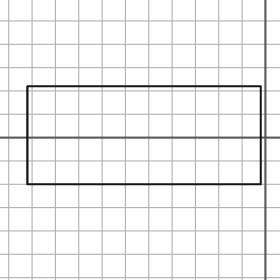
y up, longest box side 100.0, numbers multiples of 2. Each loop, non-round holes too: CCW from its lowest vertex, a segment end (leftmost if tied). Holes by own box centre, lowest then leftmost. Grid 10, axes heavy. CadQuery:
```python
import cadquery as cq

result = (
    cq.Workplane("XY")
    .moveTo(-102.0, -20.0)
    .lineTo(-2.0, -20.0)
    .lineTo(-2.0, 22.0)
    .lineTo(-102.0, 22.0)
    .close()
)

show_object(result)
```